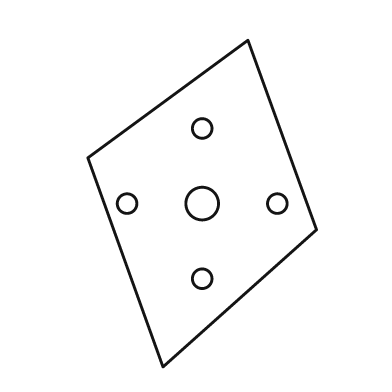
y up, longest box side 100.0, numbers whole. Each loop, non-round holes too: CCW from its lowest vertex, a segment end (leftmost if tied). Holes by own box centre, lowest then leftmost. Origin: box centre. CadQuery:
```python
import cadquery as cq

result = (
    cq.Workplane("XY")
    .moveTo(-12.0, -50.0)
    .lineTo(35.0, -8.0)
    .lineTo(14.0, 50.0)
    .lineTo(-35.0, 14.0)
    .close()
    .moveTo(0.0, -23.0)
    .circle(3.0)
    .moveTo(-23.0, 0.0)
    .circle(3.0)
    .moveTo(0.0, 0.0)
    .circle(5.0)
    .moveTo(23.0, 0.0)
    .circle(3.0)
    .moveTo(0.0, 23.0)
    .circle(3.0)
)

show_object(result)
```